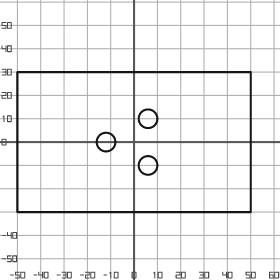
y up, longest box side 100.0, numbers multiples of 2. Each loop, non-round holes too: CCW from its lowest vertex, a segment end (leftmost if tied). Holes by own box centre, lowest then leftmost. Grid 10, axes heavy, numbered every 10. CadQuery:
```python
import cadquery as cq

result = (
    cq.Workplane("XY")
    .moveTo(-50.0, -30.0)
    .lineTo(50.0, -30.0)
    .lineTo(50.0, 30.0)
    .lineTo(-50.0, 30.0)
    .close()
    .moveTo(6.0, -10.0)
    .circle(4.0)
    .moveTo(-12.0, 0.0)
    .circle(4.0)
    .moveTo(6.0, 10.0)
    .circle(4.0)
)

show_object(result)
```